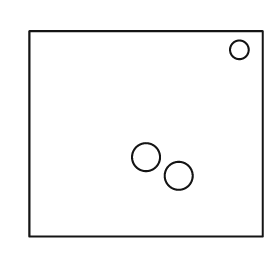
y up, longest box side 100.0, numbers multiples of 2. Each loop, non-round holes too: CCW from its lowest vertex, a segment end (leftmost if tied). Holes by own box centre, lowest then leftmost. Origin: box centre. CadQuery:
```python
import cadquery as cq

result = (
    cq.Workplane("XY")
    .moveTo(-50.0, -44.0)
    .lineTo(50.0, -44.0)
    .lineTo(50.0, 44.0)
    .lineTo(-50.0, 44.0)
    .close()
    .moveTo(14.0, -18.0)
    .circle(6.0)
    .moveTo(0.0, -10.0)
    .circle(6.0)
    .moveTo(40.0, 36.0)
    .circle(4.0)
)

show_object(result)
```